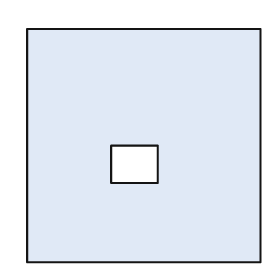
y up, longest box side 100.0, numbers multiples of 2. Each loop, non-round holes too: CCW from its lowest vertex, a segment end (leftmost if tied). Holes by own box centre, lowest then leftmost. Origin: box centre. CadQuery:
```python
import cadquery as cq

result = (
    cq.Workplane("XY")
    .moveTo(-50.0, -50.0)
    .lineTo(50.0, -50.0)
    .lineTo(50.0, 50.0)
    .lineTo(-50.0, 50.0)
    .close()
    .moveTo(-14.0, -16.0)
    .lineTo(6.0, -16.0)
    .lineTo(6.0, 0.0)
    .lineTo(-14.0, 0.0)
    .close()
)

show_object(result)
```